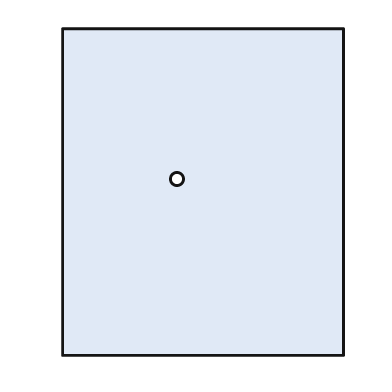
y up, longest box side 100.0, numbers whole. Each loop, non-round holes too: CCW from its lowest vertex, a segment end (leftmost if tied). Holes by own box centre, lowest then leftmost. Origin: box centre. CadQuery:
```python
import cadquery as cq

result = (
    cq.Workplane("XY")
    .moveTo(-43.0, -50.0)
    .lineTo(43.0, -50.0)
    .lineTo(43.0, 50.0)
    .lineTo(-43.0, 50.0)
    .close()
    .moveTo(-8.0, 4.0)
    .circle(2.0)
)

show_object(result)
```